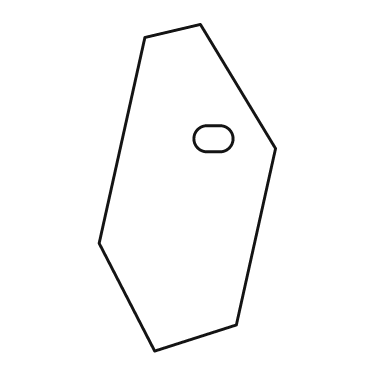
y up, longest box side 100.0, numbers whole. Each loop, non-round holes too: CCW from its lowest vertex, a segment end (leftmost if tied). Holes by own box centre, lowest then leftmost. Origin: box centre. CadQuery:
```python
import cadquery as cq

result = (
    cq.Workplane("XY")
    .moveTo(-10.0, -50.0)
    .lineTo(15.0, -42.0)
    .lineTo(27.0, 12.0)
    .lineTo(4.0, 50.0)
    .lineTo(-13.0, 46.0)
    .lineTo(-27.0, -17.0)
    .close()
    .moveTo(6.0, 11.0)
    .lineTo(10.0, 11.0)
    .threePointArc((14.0, 15.0), (10.0, 19.0))
    .lineTo(6.0, 19.0)
    .threePointArc((2.0, 15.0), (6.0, 11.0))
    .close()
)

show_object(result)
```